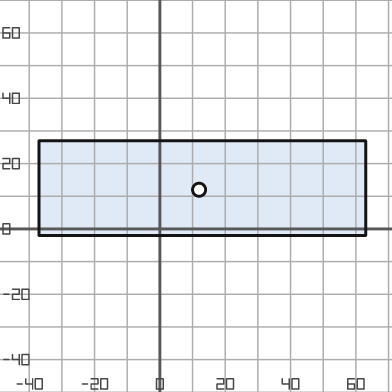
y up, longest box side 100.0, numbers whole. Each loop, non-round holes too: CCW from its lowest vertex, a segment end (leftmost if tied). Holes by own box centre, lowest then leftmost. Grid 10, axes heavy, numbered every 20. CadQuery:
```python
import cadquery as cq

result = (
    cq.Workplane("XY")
    .moveTo(-37.0, -2.0)
    .lineTo(63.0, -2.0)
    .lineTo(63.0, 27.0)
    .lineTo(-37.0, 27.0)
    .close()
    .moveTo(12.0, 12.0)
    .circle(2.0)
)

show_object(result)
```